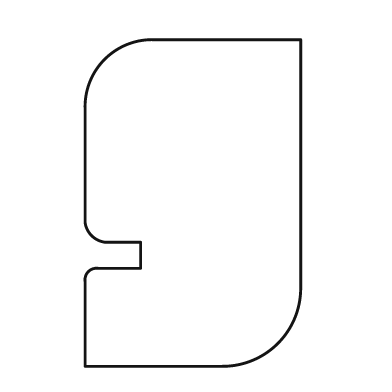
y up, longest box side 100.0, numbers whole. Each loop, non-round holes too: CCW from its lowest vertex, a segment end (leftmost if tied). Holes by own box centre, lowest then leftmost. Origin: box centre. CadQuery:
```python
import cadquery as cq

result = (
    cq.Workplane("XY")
    .moveTo(-33.0, -50.0)
    .lineTo(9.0, -50.0)
    .threePointArc((26.0, -43.0), (33.0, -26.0))
    .lineTo(33.0, 50.0)
    .lineTo(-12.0, 50.0)
    .threePointArc((-27.0, 44.0), (-33.0, 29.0))
    .lineTo(-33.0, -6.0)
    .threePointArc((-31.0, -10.0), (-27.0, -12.0))
    .lineTo(-16.0, -12.0)
    .lineTo(-16.0, -20.0)
    .lineTo(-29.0, -20.0)
    .threePointArc((-32.0, -21.0), (-33.0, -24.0))
    .close()
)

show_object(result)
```